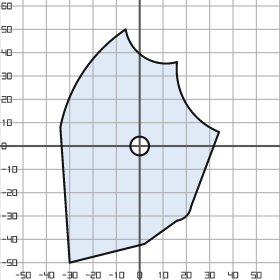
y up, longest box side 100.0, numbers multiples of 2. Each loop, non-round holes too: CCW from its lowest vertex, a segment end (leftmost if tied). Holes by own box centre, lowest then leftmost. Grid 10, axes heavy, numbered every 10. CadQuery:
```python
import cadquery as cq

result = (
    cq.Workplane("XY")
    .moveTo(-30.0, -50.0)
    .lineTo(2.0, -42.0)
    .lineTo(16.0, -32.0)
    .threePointArc((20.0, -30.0), (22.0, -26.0))
    .lineTo(34.0, 6.0)
    .threePointArc((20.0, 18.0), (16.0, 36.0))
    .threePointArc((2.0, 38.0), (-6.0, 50.0))
    .threePointArc((-24.0, 32.0), (-34.0, 8.0))
    .close()
    .moveTo(0.0, 0.0)
    .circle(4.0)
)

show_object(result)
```